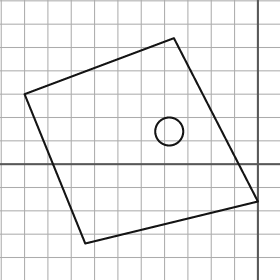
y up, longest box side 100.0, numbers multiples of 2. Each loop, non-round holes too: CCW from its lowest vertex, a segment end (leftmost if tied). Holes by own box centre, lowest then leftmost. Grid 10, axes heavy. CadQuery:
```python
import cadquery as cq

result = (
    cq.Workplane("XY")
    .moveTo(-74.0, -34.0)
    .lineTo(0.0, -16.0)
    .lineTo(-36.0, 54.0)
    .lineTo(-100.0, 30.0)
    .close()
    .moveTo(-38.0, 14.0)
    .circle(6.0)
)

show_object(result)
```